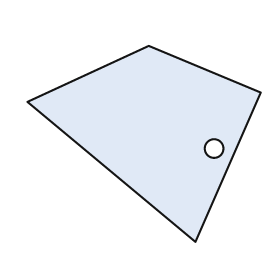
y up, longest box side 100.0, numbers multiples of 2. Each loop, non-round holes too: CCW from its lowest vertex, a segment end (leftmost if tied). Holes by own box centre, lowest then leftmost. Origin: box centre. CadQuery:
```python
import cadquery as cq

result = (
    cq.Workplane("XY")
    .moveTo(22.0, -42.0)
    .lineTo(50.0, 22.0)
    .lineTo(2.0, 42.0)
    .lineTo(-50.0, 18.0)
    .close()
    .moveTo(30.0, -2.0)
    .circle(4.0)
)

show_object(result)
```